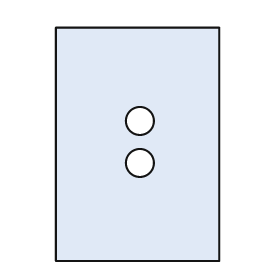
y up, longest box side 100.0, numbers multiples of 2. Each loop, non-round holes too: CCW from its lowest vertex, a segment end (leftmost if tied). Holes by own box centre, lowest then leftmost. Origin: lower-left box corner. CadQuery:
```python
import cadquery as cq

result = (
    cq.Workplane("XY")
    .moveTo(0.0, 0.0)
    .lineTo(70.0, 0.0)
    .lineTo(70.0, 100.0)
    .lineTo(0.0, 100.0)
    .close()
    .moveTo(36.0, 42.0)
    .circle(6.0)
    .moveTo(36.0, 60.0)
    .circle(6.0)
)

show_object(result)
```